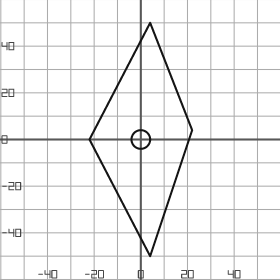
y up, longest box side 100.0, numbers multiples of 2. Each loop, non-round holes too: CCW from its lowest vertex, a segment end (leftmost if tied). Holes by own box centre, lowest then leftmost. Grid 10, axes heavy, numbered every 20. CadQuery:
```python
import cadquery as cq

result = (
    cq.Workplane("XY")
    .moveTo(4.0, -50.0)
    .lineTo(22.0, 4.0)
    .lineTo(4.0, 50.0)
    .lineTo(-22.0, 0.0)
    .close()
    .moveTo(0.0, 0.0)
    .circle(4.0)
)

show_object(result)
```